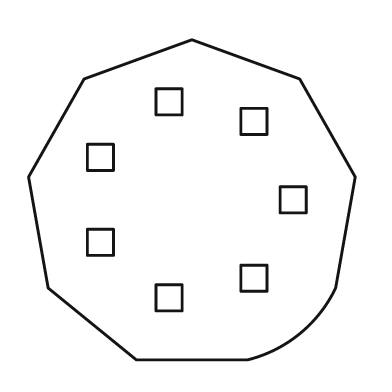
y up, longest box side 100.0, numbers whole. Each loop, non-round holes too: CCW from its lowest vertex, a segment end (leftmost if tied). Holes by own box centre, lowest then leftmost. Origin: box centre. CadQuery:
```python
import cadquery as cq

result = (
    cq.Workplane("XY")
    .moveTo(-17.0, -49.0)
    .lineTo(17.0, -49.0)
    .threePointArc((33.0, -41.0), (44.0, -27.0))
    .lineTo(50.0, 7.0)
    .lineTo(33.0, 37.0)
    .lineTo(0.0, 49.0)
    .lineTo(-33.0, 37.0)
    .lineTo(-50.0, 7.0)
    .lineTo(-44.0, -27.0)
    .close()
    .moveTo(-11.0, -34.0)
    .lineTo(-3.0, -34.0)
    .lineTo(-3.0, -26.0)
    .lineTo(-11.0, -26.0)
    .close()
    .moveTo(15.0, -28.0)
    .lineTo(23.0, -28.0)
    .lineTo(23.0, -20.0)
    .lineTo(15.0, -20.0)
    .close()
    .moveTo(-32.0, -17.0)
    .lineTo(-24.0, -17.0)
    .lineTo(-24.0, -9.0)
    .lineTo(-32.0, -9.0)
    .close()
    .moveTo(27.0, -4.0)
    .lineTo(35.0, -4.0)
    .lineTo(35.0, 4.0)
    .lineTo(27.0, 4.0)
    .close()
    .moveTo(-32.0, 9.0)
    .lineTo(-24.0, 9.0)
    .lineTo(-24.0, 17.0)
    .lineTo(-32.0, 17.0)
    .close()
    .moveTo(15.0, 20.0)
    .lineTo(23.0, 20.0)
    .lineTo(23.0, 28.0)
    .lineTo(15.0, 28.0)
    .close()
    .moveTo(-11.0, 26.0)
    .lineTo(-3.0, 26.0)
    .lineTo(-3.0, 34.0)
    .lineTo(-11.0, 34.0)
    .close()
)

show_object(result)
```